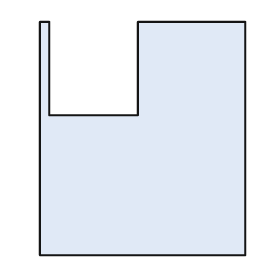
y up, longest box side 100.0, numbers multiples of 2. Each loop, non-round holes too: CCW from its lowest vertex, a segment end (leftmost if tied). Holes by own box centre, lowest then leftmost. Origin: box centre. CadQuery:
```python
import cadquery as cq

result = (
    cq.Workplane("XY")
    .moveTo(-44.0, -50.0)
    .lineTo(44.0, -50.0)
    .lineTo(44.0, 50.0)
    .lineTo(-2.0, 50.0)
    .lineTo(-2.0, 10.0)
    .lineTo(-40.0, 10.0)
    .lineTo(-40.0, 50.0)
    .lineTo(-44.0, 50.0)
    .close()
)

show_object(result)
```